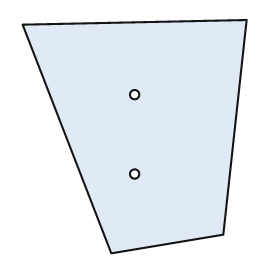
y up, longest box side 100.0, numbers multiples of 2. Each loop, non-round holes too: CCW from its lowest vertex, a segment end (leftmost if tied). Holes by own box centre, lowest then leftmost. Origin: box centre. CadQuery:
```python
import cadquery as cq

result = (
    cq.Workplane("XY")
    .moveTo(-10.0, -50.0)
    .lineTo(38.0, -42.0)
    .lineTo(48.0, 50.0)
    .lineTo(-48.0, 48.0)
    .close()
    .moveTo(0.0, -16.0)
    .circle(2.0)
    .moveTo(0.0, 18.0)
    .circle(2.0)
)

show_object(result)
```